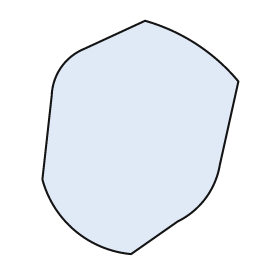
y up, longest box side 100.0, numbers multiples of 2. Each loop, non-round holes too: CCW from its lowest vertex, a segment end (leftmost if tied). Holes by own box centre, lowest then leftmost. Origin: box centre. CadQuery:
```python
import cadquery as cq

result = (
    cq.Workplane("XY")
    .moveTo(-4.0, -50.0)
    .lineTo(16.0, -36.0)
    .threePointArc((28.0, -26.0), (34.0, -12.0))
    .lineTo(42.0, 24.0)
    .threePointArc((24.0, 40.0), (2.0, 50.0))
    .lineTo(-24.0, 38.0)
    .threePointArc((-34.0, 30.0), (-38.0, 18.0))
    .lineTo(-42.0, -18.0)
    .threePointArc((-28.0, -40.0), (-4.0, -50.0))
    .close()
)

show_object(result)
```